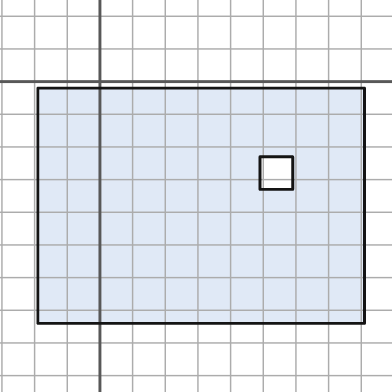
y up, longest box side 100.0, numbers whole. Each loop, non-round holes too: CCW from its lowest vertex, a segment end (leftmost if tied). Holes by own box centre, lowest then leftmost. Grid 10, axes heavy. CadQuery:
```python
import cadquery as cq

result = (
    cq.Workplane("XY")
    .moveTo(-19.0, -74.0)
    .lineTo(81.0, -74.0)
    .lineTo(81.0, -2.0)
    .lineTo(-19.0, -2.0)
    .close()
    .moveTo(49.0, -33.0)
    .lineTo(59.0, -33.0)
    .lineTo(59.0, -23.0)
    .lineTo(49.0, -23.0)
    .close()
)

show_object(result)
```